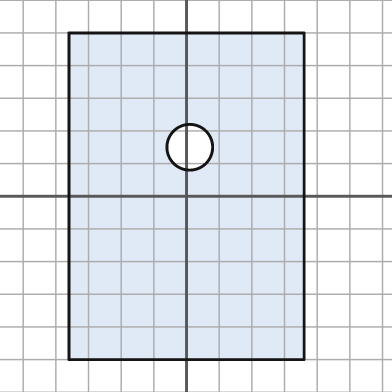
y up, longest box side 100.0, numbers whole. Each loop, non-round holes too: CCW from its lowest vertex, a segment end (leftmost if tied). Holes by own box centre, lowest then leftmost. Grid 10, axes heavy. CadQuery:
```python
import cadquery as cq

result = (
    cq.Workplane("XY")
    .moveTo(-36.0, -50.0)
    .lineTo(36.0, -50.0)
    .lineTo(36.0, 50.0)
    .lineTo(-36.0, 50.0)
    .close()
    .moveTo(1.0, 15.0)
    .circle(7.0)
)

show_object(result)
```